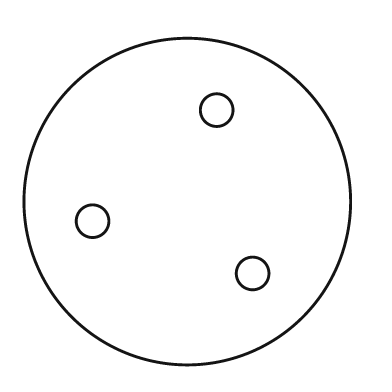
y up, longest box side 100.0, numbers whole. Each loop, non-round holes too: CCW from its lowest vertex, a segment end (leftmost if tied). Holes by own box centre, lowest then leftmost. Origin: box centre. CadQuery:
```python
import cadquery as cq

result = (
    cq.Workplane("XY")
    .moveTo(0.0, 0.0)
    .circle(50.0)
    .moveTo(20.0, -22.0)
    .circle(5.0)
    .moveTo(-29.0, -6.0)
    .circle(5.0)
    .moveTo(9.0, 28.0)
    .circle(5.0)
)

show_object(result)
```